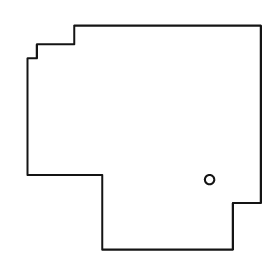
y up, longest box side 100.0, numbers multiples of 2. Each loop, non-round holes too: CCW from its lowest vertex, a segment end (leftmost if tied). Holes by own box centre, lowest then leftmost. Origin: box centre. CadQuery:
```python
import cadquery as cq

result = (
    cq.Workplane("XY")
    .moveTo(-18.0, -48.0)
    .lineTo(38.0, -48.0)
    .lineTo(38.0, -28.0)
    .lineTo(50.0, -28.0)
    .lineTo(50.0, 48.0)
    .lineTo(-30.0, 48.0)
    .lineTo(-30.0, 40.0)
    .lineTo(-46.0, 40.0)
    .lineTo(-46.0, 34.0)
    .lineTo(-50.0, 34.0)
    .lineTo(-50.0, -16.0)
    .lineTo(-18.0, -16.0)
    .close()
    .moveTo(28.0, -18.0)
    .circle(2.0)
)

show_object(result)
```